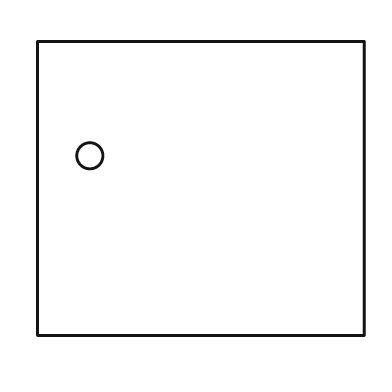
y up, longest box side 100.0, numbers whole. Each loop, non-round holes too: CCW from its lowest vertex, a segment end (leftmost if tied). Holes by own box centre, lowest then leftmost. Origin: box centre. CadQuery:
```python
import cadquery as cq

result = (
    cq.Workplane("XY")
    .moveTo(-50.0, -45.0)
    .lineTo(50.0, -45.0)
    .lineTo(50.0, 45.0)
    .lineTo(-50.0, 45.0)
    .close()
    .moveTo(-34.0, 10.0)
    .circle(4.0)
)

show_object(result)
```